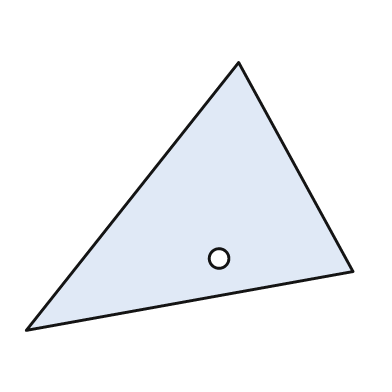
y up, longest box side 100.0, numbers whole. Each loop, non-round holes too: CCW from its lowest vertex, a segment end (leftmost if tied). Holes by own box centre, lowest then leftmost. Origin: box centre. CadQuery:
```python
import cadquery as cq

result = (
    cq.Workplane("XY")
    .moveTo(-50.0, -41.0)
    .lineTo(50.0, -23.0)
    .lineTo(15.0, 41.0)
    .close()
    .moveTo(9.0, -19.0)
    .circle(3.0)
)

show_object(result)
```